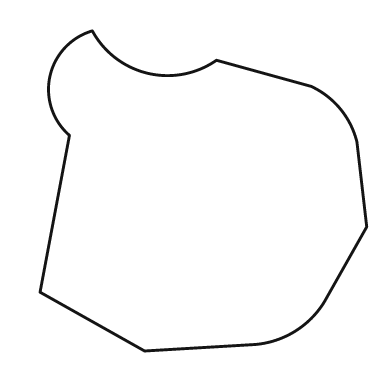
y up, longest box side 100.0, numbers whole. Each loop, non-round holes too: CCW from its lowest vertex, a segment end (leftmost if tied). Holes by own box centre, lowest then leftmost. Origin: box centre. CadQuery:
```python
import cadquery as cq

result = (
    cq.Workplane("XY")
    .moveTo(-18.0, -49.0)
    .lineTo(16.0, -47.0)
    .threePointArc((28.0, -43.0), (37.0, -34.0))
    .lineTo(50.0, -11.0)
    .lineTo(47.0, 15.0)
    .threePointArc((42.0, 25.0), (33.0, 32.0))
    .lineTo(4.0, 40.0)
    .threePointArc((-17.0, 36.0), (-34.0, 49.0))
    .threePointArc((-47.0, 35.0), (-41.0, 17.0))
    .lineTo(-50.0, -31.0)
    .close()
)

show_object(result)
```